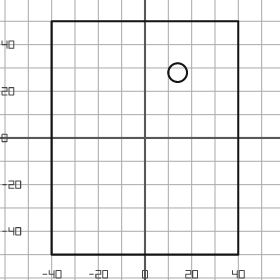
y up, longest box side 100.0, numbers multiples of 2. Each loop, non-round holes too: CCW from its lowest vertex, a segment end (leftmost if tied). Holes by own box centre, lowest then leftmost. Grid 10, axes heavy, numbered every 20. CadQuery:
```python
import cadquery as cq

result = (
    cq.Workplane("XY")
    .moveTo(-40.0, -50.0)
    .lineTo(40.0, -50.0)
    .lineTo(40.0, 50.0)
    .lineTo(-40.0, 50.0)
    .close()
    .moveTo(14.0, 28.0)
    .circle(4.0)
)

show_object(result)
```